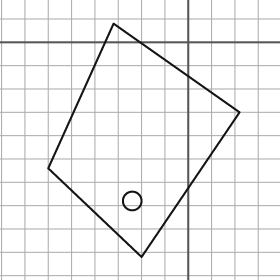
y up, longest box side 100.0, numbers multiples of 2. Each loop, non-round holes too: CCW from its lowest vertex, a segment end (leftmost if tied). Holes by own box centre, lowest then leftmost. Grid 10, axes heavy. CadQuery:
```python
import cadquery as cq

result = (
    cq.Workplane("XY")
    .moveTo(-20.0, -92.0)
    .lineTo(22.0, -30.0)
    .lineTo(-32.0, 8.0)
    .lineTo(-60.0, -54.0)
    .close()
    .moveTo(-24.0, -68.0)
    .circle(4.0)
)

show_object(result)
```